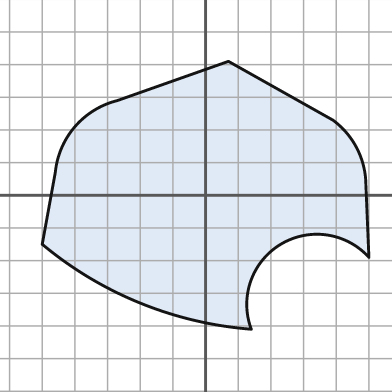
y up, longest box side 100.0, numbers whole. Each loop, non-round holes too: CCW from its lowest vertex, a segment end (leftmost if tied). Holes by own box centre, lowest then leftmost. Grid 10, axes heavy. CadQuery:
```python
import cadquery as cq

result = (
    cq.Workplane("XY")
    .moveTo(14.0, -41.0)
    .threePointArc((23.0, -15.0), (50.0, -19.0))
    .lineTo(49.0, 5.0)
    .threePointArc((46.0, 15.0), (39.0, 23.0))
    .lineTo(7.0, 41.0)
    .lineTo(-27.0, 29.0)
    .threePointArc((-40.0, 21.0), (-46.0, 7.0))
    .lineTo(-50.0, -15.0)
    .threePointArc((-20.0, -33.0), (14.0, -41.0))
    .close()
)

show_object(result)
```